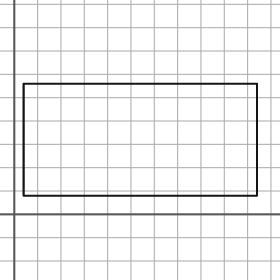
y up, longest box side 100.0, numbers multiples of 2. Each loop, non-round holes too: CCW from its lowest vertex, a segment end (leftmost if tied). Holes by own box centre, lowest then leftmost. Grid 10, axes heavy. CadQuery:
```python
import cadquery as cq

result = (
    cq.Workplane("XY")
    .moveTo(4.0, 8.0)
    .lineTo(104.0, 8.0)
    .lineTo(104.0, 56.0)
    .lineTo(4.0, 56.0)
    .close()
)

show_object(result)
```